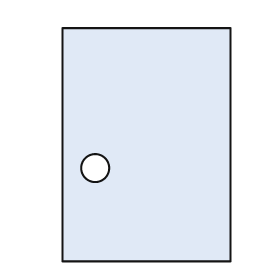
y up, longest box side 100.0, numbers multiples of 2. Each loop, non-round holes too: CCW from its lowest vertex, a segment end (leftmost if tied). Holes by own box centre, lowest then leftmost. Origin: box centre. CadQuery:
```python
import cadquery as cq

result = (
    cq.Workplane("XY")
    .moveTo(-36.0, -50.0)
    .lineTo(36.0, -50.0)
    .lineTo(36.0, 50.0)
    .lineTo(-36.0, 50.0)
    .close()
    .moveTo(-22.0, -10.0)
    .circle(6.0)
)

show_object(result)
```